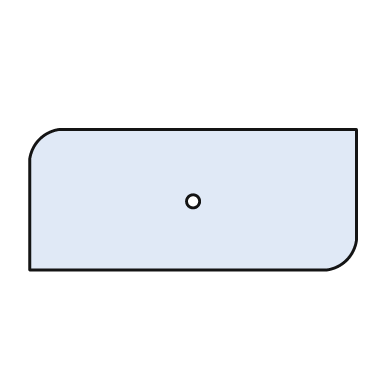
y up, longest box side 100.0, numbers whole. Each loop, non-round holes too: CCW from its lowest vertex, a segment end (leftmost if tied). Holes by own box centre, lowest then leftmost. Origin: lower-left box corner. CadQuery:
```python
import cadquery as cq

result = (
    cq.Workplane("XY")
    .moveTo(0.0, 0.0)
    .lineTo(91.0, 0.0)
    .threePointArc((97.0, 3.0), (100.0, 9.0))
    .lineTo(100.0, 43.0)
    .lineTo(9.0, 43.0)
    .threePointArc((3.0, 40.0), (0.0, 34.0))
    .close()
    .moveTo(50.0, 21.0)
    .circle(2.0)
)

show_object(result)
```